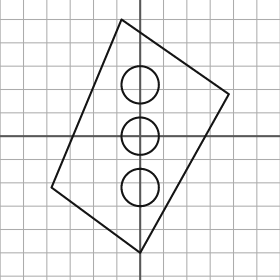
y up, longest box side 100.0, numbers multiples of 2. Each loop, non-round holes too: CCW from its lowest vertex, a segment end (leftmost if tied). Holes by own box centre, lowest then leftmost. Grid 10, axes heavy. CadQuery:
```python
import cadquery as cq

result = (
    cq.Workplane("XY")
    .moveTo(0.0, -50.0)
    .lineTo(38.0, 18.0)
    .lineTo(-8.0, 50.0)
    .lineTo(-38.0, -22.0)
    .close()
    .moveTo(0.0, -22.0)
    .circle(8.0)
    .moveTo(0.0, 0.0)
    .circle(8.0)
    .moveTo(0.0, 22.0)
    .circle(8.0)
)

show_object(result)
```